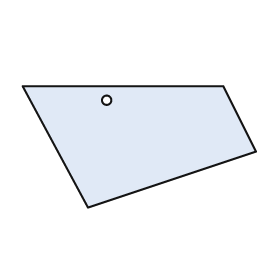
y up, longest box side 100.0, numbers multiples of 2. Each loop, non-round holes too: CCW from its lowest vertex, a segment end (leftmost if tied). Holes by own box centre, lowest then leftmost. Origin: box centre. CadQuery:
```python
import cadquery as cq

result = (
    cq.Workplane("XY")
    .moveTo(-22.0, -26.0)
    .lineTo(50.0, -2.0)
    .lineTo(36.0, 26.0)
    .lineTo(-50.0, 26.0)
    .close()
    .moveTo(-14.0, 20.0)
    .circle(2.0)
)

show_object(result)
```